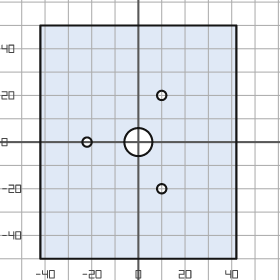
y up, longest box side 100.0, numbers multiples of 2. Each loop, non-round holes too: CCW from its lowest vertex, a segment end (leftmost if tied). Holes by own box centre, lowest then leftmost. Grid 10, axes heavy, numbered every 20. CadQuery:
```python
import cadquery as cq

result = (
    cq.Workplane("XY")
    .moveTo(-42.0, -50.0)
    .lineTo(42.0, -50.0)
    .lineTo(42.0, 50.0)
    .lineTo(-42.0, 50.0)
    .close()
    .moveTo(10.0, -20.0)
    .circle(2.0)
    .moveTo(-22.0, 0.0)
    .circle(2.0)
    .moveTo(0.0, 0.0)
    .circle(6.0)
    .moveTo(10.0, 20.0)
    .circle(2.0)
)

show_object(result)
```